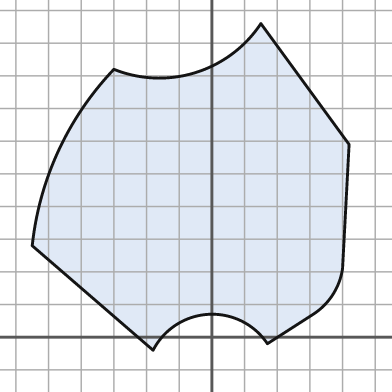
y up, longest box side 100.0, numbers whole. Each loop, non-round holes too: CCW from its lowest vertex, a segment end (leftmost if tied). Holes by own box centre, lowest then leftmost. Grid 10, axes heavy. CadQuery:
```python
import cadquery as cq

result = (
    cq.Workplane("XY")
    .moveTo(-18.0, -4.0)
    .threePointArc((-1.0, 7.0), (17.0, -2.0))
    .lineTo(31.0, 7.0)
    .threePointArc((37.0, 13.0), (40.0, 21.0))
    .lineTo(42.0, 59.0)
    .lineTo(15.0, 96.0)
    .threePointArc((-5.0, 81.0), (-30.0, 82.0))
    .threePointArc((-47.0, 57.0), (-55.0, 28.0))
    .close()
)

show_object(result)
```